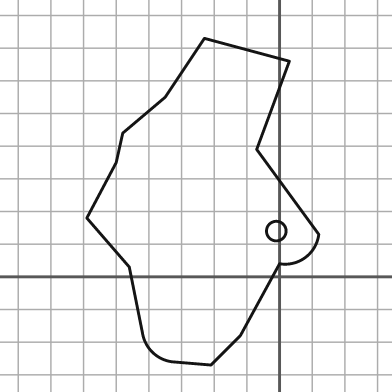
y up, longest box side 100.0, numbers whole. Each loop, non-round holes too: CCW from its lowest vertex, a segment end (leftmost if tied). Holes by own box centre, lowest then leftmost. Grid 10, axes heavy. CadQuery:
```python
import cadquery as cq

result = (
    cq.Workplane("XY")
    .moveTo(-21.0, -27.0)
    .lineTo(-12.0, -18.0)
    .lineTo(0.0, 4.0)
    .threePointArc((8.0, 6.0), (12.0, 13.0))
    .lineTo(-7.0, 39.0)
    .lineTo(3.0, 66.0)
    .lineTo(-23.0, 73.0)
    .lineTo(-35.0, 55.0)
    .lineTo(-48.0, 44.0)
    .lineTo(-50.0, 35.0)
    .lineTo(-59.0, 18.0)
    .lineTo(-46.0, 3.0)
    .lineTo(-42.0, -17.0)
    .threePointArc((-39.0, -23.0), (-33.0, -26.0))
    .close()
    .moveTo(-1.0, 14.0)
    .circle(3.0)
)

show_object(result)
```